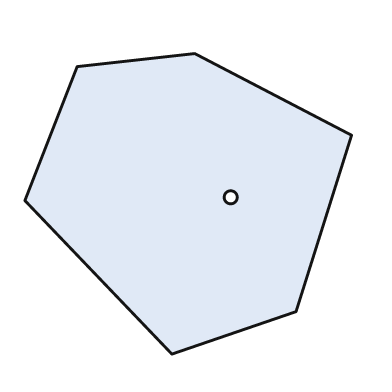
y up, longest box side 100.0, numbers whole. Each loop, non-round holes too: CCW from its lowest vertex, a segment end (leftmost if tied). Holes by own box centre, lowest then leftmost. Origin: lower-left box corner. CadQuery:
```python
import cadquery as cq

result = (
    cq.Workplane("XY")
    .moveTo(45.0, 0.0)
    .lineTo(83.0, 13.0)
    .lineTo(100.0, 67.0)
    .lineTo(52.0, 92.0)
    .lineTo(16.0, 88.0)
    .lineTo(0.0, 47.0)
    .close()
    .moveTo(63.0, 48.0)
    .circle(2.0)
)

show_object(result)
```